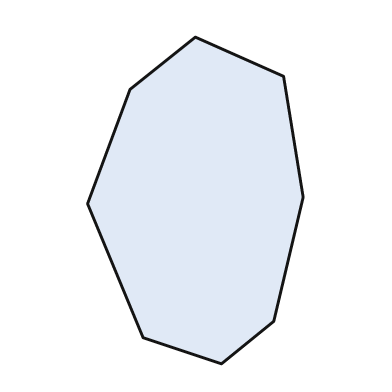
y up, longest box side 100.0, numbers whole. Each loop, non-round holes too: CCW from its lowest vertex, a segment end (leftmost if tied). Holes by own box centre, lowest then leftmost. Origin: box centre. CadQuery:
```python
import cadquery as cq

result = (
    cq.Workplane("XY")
    .moveTo(8.0, -50.0)
    .lineTo(24.0, -37.0)
    .lineTo(33.0, 1.0)
    .lineTo(27.0, 38.0)
    .lineTo(0.0, 50.0)
    .lineTo(-20.0, 34.0)
    .lineTo(-33.0, -1.0)
    .lineTo(-16.0, -42.0)
    .close()
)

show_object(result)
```